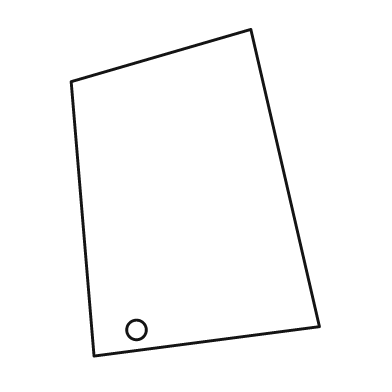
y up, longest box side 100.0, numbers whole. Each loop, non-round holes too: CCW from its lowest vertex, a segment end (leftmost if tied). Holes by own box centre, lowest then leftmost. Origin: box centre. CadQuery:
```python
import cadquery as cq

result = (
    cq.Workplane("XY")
    .moveTo(-31.0, -50.0)
    .lineTo(38.0, -41.0)
    .lineTo(17.0, 50.0)
    .lineTo(-38.0, 34.0)
    .close()
    .moveTo(-18.0, -42.0)
    .circle(3.0)
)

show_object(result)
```